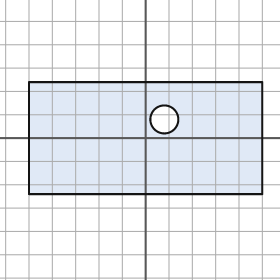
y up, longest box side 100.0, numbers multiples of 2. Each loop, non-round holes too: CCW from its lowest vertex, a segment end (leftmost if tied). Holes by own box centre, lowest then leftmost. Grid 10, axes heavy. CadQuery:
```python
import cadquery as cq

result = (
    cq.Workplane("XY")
    .moveTo(-50.0, -24.0)
    .lineTo(50.0, -24.0)
    .lineTo(50.0, 24.0)
    .lineTo(-50.0, 24.0)
    .close()
    .moveTo(8.0, 8.0)
    .circle(6.0)
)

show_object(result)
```